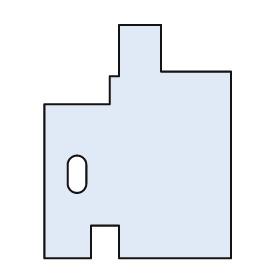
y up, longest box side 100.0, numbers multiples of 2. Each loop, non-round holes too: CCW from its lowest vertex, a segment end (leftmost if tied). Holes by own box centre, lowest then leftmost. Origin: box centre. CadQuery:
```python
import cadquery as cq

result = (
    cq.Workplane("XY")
    .moveTo(-40.0, -50.0)
    .lineTo(-20.0, -50.0)
    .lineTo(-20.0, -36.0)
    .lineTo(-8.0, -36.0)
    .lineTo(-8.0, -50.0)
    .lineTo(40.0, -50.0)
    .lineTo(40.0, 30.0)
    .lineTo(10.0, 30.0)
    .lineTo(10.0, 50.0)
    .lineTo(-8.0, 50.0)
    .lineTo(-8.0, 28.0)
    .lineTo(-12.0, 28.0)
    .lineTo(-12.0, 16.0)
    .lineTo(-40.0, 16.0)
    .close()
    .moveTo(-30.0, -18.0)
    .threePointArc((-26.0, -22.0), (-22.0, -18.0))
    .lineTo(-22.0, -10.0)
    .threePointArc((-26.0, -6.0), (-30.0, -10.0))
    .close()
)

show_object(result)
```